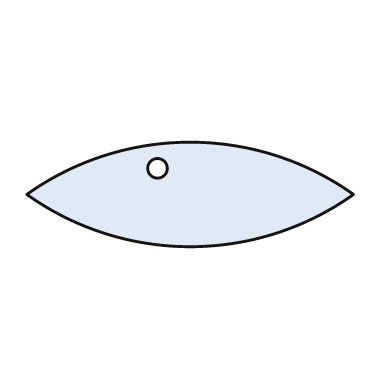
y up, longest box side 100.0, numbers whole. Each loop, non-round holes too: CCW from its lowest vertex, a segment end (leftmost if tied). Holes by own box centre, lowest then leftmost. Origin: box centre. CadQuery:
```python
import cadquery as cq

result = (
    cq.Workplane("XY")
    .moveTo(-50.0, 0.0)
    .threePointArc((0.0, -16.0), (50.0, 0.0))
    .threePointArc((0.0, 16.0), (-50.0, 0.0))
    .close()
    .moveTo(-10.0, 8.0)
    .circle(3.0)
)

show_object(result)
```